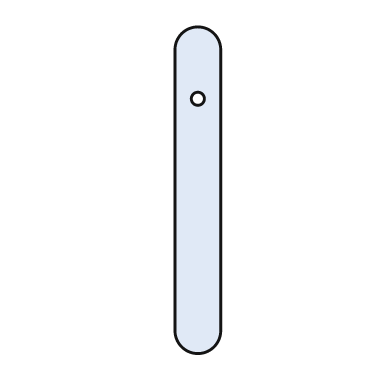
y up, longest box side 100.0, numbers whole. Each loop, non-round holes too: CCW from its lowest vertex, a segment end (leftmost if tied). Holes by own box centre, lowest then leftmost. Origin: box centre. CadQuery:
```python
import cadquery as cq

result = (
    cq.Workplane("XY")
    .moveTo(-7.0, -43.0)
    .threePointArc((0.0, -50.0), (7.0, -43.0))
    .lineTo(7.0, 43.0)
    .threePointArc((0.0, 50.0), (-7.0, 43.0))
    .close()
    .moveTo(0.0, 28.0)
    .circle(2.0)
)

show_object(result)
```